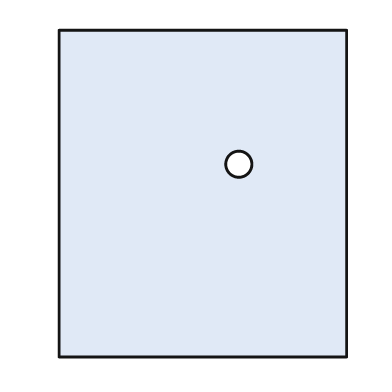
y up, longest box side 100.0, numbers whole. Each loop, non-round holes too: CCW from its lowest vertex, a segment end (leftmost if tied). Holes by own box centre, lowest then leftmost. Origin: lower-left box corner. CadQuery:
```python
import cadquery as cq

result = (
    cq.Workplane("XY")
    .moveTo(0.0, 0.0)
    .lineTo(88.0, 0.0)
    .lineTo(88.0, 100.0)
    .lineTo(0.0, 100.0)
    .close()
    .moveTo(55.0, 59.0)
    .circle(4.0)
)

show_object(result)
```